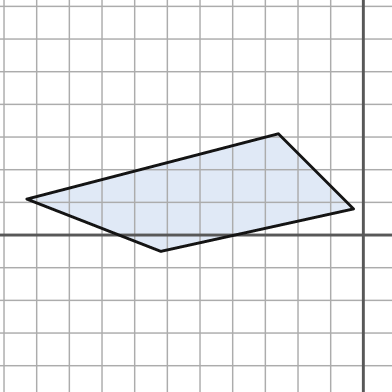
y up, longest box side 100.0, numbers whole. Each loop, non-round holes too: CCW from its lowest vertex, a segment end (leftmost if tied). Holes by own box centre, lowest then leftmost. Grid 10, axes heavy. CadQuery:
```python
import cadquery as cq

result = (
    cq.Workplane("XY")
    .moveTo(-62.0, -5.0)
    .lineTo(-3.0, 8.0)
    .lineTo(-26.0, 31.0)
    .lineTo(-103.0, 11.0)
    .close()
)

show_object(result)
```